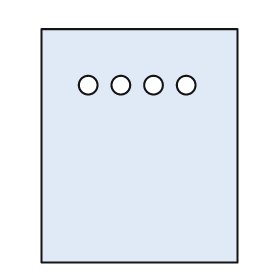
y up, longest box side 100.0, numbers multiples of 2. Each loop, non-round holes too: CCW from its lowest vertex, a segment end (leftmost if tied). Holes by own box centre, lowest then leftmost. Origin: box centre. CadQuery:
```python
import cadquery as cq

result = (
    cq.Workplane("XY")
    .moveTo(-42.0, -50.0)
    .lineTo(42.0, -50.0)
    .lineTo(42.0, 50.0)
    .lineTo(-42.0, 50.0)
    .close()
    .moveTo(-22.0, 26.0)
    .circle(4.0)
    .moveTo(-8.0, 26.0)
    .circle(4.0)
    .moveTo(6.0, 26.0)
    .circle(4.0)
    .moveTo(20.0, 26.0)
    .circle(4.0)
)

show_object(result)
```